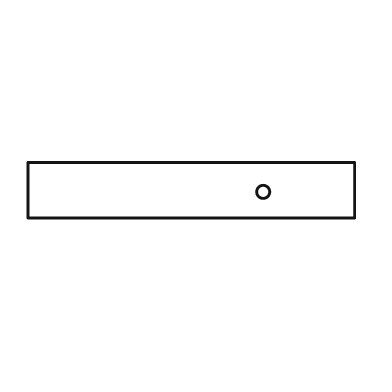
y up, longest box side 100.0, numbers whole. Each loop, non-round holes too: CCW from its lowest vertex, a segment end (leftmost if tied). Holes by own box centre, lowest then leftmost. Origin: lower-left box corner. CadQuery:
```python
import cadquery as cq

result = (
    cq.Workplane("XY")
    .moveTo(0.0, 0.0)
    .lineTo(100.0, 0.0)
    .lineTo(100.0, 17.0)
    .lineTo(0.0, 17.0)
    .close()
    .moveTo(72.0, 8.0)
    .circle(2.0)
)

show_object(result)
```